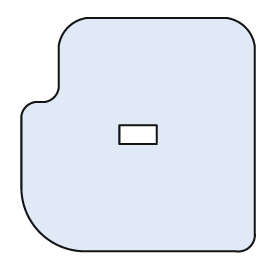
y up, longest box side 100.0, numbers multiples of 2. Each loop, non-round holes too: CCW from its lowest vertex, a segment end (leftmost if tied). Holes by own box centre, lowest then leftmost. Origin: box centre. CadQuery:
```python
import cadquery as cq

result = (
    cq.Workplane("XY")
    .moveTo(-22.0, -50.0)
    .lineTo(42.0, -50.0)
    .threePointArc((48.0, -48.0), (50.0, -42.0))
    .lineTo(50.0, 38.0)
    .threePointArc((46.0, 46.0), (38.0, 50.0))
    .lineTo(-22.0, 50.0)
    .threePointArc((-30.0, 46.0), (-34.0, 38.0))
    .lineTo(-34.0, 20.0)
    .threePointArc((-36.0, 16.0), (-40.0, 14.0))
    .lineTo(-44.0, 14.0)
    .threePointArc((-48.0, 12.0), (-50.0, 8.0))
    .lineTo(-50.0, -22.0)
    .threePointArc((-42.0, -42.0), (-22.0, -50.0))
    .close()
    .moveTo(-8.0, -4.0)
    .lineTo(8.0, -4.0)
    .lineTo(8.0, 4.0)
    .lineTo(-8.0, 4.0)
    .close()
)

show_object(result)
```